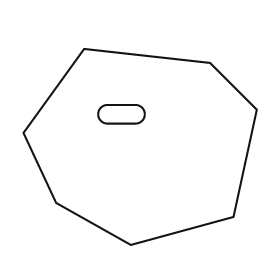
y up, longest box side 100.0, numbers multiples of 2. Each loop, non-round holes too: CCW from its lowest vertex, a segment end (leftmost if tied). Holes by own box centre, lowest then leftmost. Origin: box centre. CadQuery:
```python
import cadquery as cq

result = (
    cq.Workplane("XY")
    .moveTo(-4.0, -42.0)
    .lineTo(40.0, -30.0)
    .lineTo(50.0, 16.0)
    .lineTo(30.0, 36.0)
    .lineTo(-24.0, 42.0)
    .lineTo(-50.0, 6.0)
    .lineTo(-36.0, -24.0)
    .close()
    .moveTo(-14.0, 10.0)
    .lineTo(-2.0, 10.0)
    .threePointArc((2.0, 14.0), (-2.0, 18.0))
    .lineTo(-14.0, 18.0)
    .threePointArc((-18.0, 14.0), (-14.0, 10.0))
    .close()
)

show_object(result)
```